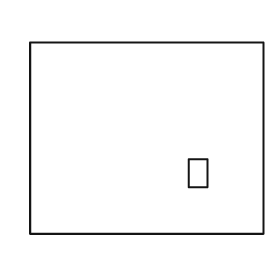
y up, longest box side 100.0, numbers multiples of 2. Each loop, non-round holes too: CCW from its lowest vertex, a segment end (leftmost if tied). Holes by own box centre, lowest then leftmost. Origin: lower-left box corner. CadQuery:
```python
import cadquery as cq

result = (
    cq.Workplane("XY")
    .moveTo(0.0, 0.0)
    .lineTo(100.0, 0.0)
    .lineTo(100.0, 82.0)
    .lineTo(0.0, 82.0)
    .close()
    .moveTo(68.0, 20.0)
    .lineTo(76.0, 20.0)
    .lineTo(76.0, 32.0)
    .lineTo(68.0, 32.0)
    .close()
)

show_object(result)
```